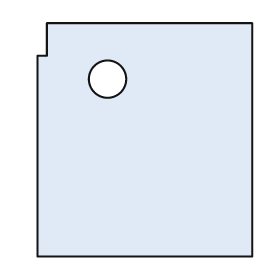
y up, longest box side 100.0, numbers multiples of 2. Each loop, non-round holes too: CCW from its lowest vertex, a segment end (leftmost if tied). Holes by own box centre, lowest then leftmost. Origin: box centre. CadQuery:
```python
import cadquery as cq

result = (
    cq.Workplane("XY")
    .moveTo(-46.0, -50.0)
    .lineTo(46.0, -50.0)
    .lineTo(46.0, 50.0)
    .lineTo(-42.0, 50.0)
    .lineTo(-42.0, 36.0)
    .lineTo(-46.0, 36.0)
    .close()
    .moveTo(-16.0, 26.0)
    .circle(8.0)
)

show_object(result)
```